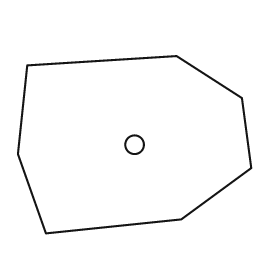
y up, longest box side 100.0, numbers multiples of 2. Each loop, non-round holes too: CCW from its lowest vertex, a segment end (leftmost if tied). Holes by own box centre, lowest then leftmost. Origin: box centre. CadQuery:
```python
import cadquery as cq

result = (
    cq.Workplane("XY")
    .moveTo(-38.0, -38.0)
    .lineTo(20.0, -32.0)
    .lineTo(50.0, -10.0)
    .lineTo(46.0, 20.0)
    .lineTo(18.0, 38.0)
    .lineTo(-46.0, 34.0)
    .lineTo(-50.0, -4.0)
    .close()
    .moveTo(0.0, 0.0)
    .circle(4.0)
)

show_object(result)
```